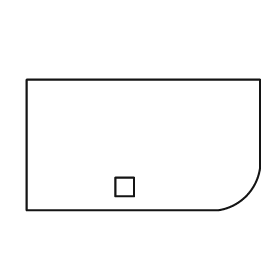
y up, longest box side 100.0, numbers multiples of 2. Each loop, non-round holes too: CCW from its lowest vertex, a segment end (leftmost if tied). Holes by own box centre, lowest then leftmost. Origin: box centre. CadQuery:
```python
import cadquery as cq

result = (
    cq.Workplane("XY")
    .moveTo(-50.0, -28.0)
    .lineTo(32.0, -28.0)
    .threePointArc((44.0, -22.0), (50.0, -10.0))
    .lineTo(50.0, 28.0)
    .lineTo(-50.0, 28.0)
    .close()
    .moveTo(-12.0, -22.0)
    .lineTo(-4.0, -22.0)
    .lineTo(-4.0, -14.0)
    .lineTo(-12.0, -14.0)
    .close()
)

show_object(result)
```